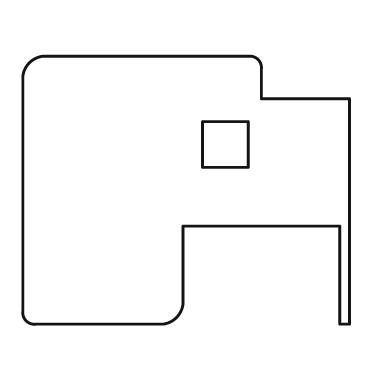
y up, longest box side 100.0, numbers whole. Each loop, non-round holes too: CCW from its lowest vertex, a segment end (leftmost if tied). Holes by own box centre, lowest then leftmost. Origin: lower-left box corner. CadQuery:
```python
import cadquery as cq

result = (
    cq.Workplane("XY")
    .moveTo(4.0, 0.0)
    .lineTo(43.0, 0.0)
    .threePointArc((47.0, 2.0), (49.0, 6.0))
    .lineTo(49.0, 30.0)
    .lineTo(97.0, 30.0)
    .lineTo(97.0, 0.0)
    .lineTo(100.0, 0.0)
    .lineTo(100.0, 69.0)
    .lineTo(73.0, 69.0)
    .lineTo(73.0, 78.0)
    .threePointArc((72.0, 81.0), (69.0, 82.0))
    .lineTo(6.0, 82.0)
    .threePointArc((2.0, 80.0), (0.0, 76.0))
    .lineTo(0.0, 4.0)
    .threePointArc((1.0, 1.0), (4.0, 0.0))
    .close()
    .moveTo(55.0, 48.0)
    .lineTo(69.0, 48.0)
    .lineTo(69.0, 62.0)
    .lineTo(55.0, 62.0)
    .close()
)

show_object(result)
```